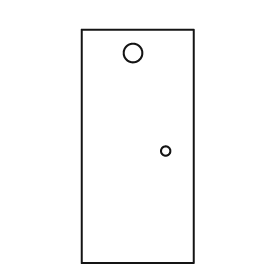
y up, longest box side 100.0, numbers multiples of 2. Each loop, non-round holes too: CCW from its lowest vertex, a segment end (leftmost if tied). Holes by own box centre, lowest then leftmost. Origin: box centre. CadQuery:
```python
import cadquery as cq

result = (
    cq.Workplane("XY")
    .moveTo(-24.0, -50.0)
    .lineTo(24.0, -50.0)
    .lineTo(24.0, 50.0)
    .lineTo(-24.0, 50.0)
    .close()
    .moveTo(12.0, -2.0)
    .circle(2.0)
    .moveTo(-2.0, 40.0)
    .circle(4.0)
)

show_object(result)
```